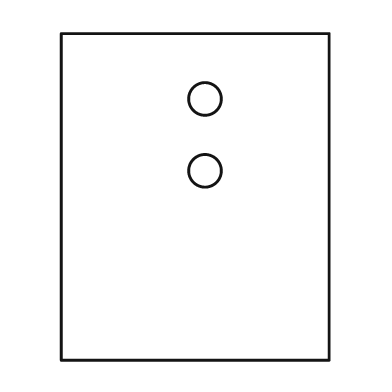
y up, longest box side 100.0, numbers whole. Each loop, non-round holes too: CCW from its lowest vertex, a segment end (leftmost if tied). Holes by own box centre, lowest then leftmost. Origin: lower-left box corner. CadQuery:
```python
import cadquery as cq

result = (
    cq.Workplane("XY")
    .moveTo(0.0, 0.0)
    .lineTo(82.0, 0.0)
    .lineTo(82.0, 100.0)
    .lineTo(0.0, 100.0)
    .close()
    .moveTo(44.0, 58.0)
    .circle(5.0)
    .moveTo(44.0, 80.0)
    .circle(5.0)
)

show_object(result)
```